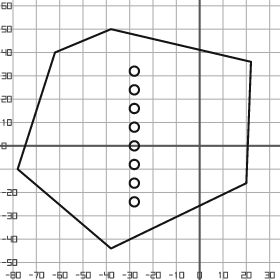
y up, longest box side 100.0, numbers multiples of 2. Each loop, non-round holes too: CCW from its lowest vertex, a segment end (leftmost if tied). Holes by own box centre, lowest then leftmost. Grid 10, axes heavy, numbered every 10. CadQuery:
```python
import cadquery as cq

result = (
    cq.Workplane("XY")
    .moveTo(-38.0, -44.0)
    .lineTo(20.0, -16.0)
    .lineTo(22.0, 36.0)
    .lineTo(-38.0, 50.0)
    .lineTo(-62.0, 40.0)
    .lineTo(-78.0, -10.0)
    .close()
    .moveTo(-28.0, -24.0)
    .circle(2.0)
    .moveTo(-28.0, -16.0)
    .circle(2.0)
    .moveTo(-28.0, -8.0)
    .circle(2.0)
    .moveTo(-28.0, 0.0)
    .circle(2.0)
    .moveTo(-28.0, 8.0)
    .circle(2.0)
    .moveTo(-28.0, 16.0)
    .circle(2.0)
    .moveTo(-28.0, 24.0)
    .circle(2.0)
    .moveTo(-28.0, 32.0)
    .circle(2.0)
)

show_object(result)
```